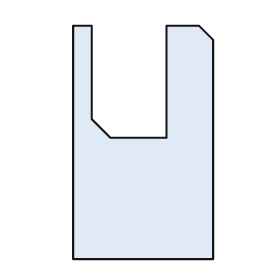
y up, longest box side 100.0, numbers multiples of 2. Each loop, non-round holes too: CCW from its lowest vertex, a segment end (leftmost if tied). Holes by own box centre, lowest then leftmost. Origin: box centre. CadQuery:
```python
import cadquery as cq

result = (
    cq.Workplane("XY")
    .moveTo(-30.0, -50.0)
    .lineTo(30.0, -50.0)
    .lineTo(30.0, 44.0)
    .lineTo(24.0, 50.0)
    .lineTo(10.0, 50.0)
    .lineTo(10.0, 2.0)
    .lineTo(-14.0, 2.0)
    .lineTo(-22.0, 10.0)
    .lineTo(-22.0, 50.0)
    .lineTo(-30.0, 50.0)
    .close()
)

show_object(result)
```